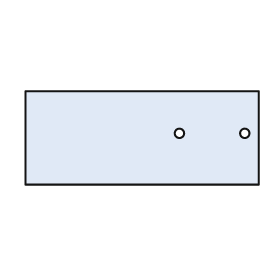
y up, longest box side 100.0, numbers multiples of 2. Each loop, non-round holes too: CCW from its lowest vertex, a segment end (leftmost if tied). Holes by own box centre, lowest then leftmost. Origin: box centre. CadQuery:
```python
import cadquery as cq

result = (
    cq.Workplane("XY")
    .moveTo(-50.0, -20.0)
    .lineTo(50.0, -20.0)
    .lineTo(50.0, 20.0)
    .lineTo(-50.0, 20.0)
    .close()
    .moveTo(16.0, 2.0)
    .circle(2.0)
    .moveTo(44.0, 2.0)
    .circle(2.0)
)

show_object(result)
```